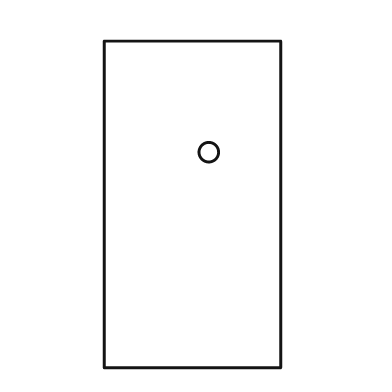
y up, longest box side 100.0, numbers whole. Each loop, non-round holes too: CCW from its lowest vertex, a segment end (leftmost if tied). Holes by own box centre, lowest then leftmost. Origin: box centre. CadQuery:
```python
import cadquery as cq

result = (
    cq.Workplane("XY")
    .moveTo(-27.0, -50.0)
    .lineTo(27.0, -50.0)
    .lineTo(27.0, 50.0)
    .lineTo(-27.0, 50.0)
    .close()
    .moveTo(5.0, 16.0)
    .circle(3.0)
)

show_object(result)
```